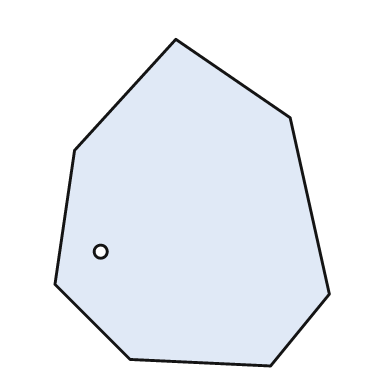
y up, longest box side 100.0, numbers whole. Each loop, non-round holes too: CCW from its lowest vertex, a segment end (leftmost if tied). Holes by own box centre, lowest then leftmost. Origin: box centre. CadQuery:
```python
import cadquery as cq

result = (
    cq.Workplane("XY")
    .moveTo(24.0, -50.0)
    .lineTo(42.0, -28.0)
    .lineTo(30.0, 26.0)
    .lineTo(-5.0, 50.0)
    .lineTo(-36.0, 16.0)
    .lineTo(-42.0, -25.0)
    .lineTo(-19.0, -48.0)
    .close()
    .moveTo(-28.0, -15.0)
    .circle(2.0)
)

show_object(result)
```